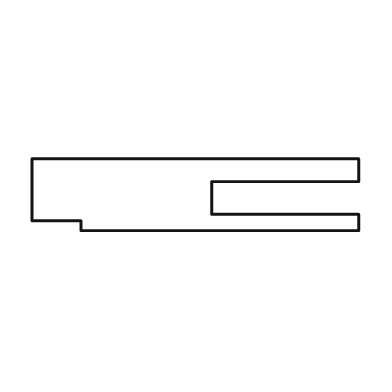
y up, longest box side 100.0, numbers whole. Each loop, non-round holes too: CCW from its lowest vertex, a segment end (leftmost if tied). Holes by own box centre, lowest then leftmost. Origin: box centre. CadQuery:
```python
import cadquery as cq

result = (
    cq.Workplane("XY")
    .moveTo(-35.0, -11.0)
    .lineTo(50.0, -11.0)
    .lineTo(50.0, -6.0)
    .lineTo(5.0, -6.0)
    .lineTo(5.0, 4.0)
    .lineTo(50.0, 4.0)
    .lineTo(50.0, 11.0)
    .lineTo(-50.0, 11.0)
    .lineTo(-50.0, -8.0)
    .lineTo(-35.0, -8.0)
    .close()
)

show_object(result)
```